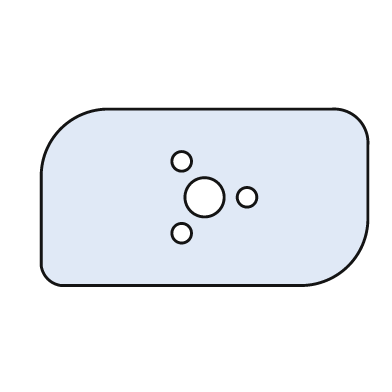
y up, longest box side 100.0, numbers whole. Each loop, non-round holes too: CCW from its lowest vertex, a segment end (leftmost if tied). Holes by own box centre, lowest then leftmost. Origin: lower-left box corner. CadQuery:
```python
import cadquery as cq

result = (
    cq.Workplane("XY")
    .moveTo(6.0, 0.0)
    .lineTo(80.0, 0.0)
    .threePointArc((94.0, 6.0), (100.0, 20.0))
    .lineTo(100.0, 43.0)
    .threePointArc((97.0, 51.0), (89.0, 54.0))
    .lineTo(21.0, 54.0)
    .threePointArc((6.0, 48.0), (0.0, 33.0))
    .lineTo(0.0, 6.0)
    .threePointArc((2.0, 2.0), (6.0, 0.0))
    .close()
    .moveTo(43.0, 16.0)
    .circle(3.0)
    .moveTo(50.0, 27.0)
    .circle(6.0)
    .moveTo(63.0, 27.0)
    .circle(3.0)
    .moveTo(43.0, 38.0)
    .circle(3.0)
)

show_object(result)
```